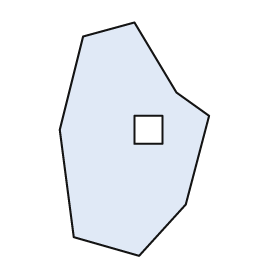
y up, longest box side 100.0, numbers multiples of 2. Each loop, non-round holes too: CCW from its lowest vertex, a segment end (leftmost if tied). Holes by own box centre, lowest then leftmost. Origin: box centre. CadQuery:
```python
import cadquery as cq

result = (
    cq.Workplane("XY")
    .moveTo(2.0, -50.0)
    .lineTo(22.0, -28.0)
    .lineTo(32.0, 10.0)
    .lineTo(18.0, 20.0)
    .lineTo(0.0, 50.0)
    .lineTo(-22.0, 44.0)
    .lineTo(-32.0, 4.0)
    .lineTo(-26.0, -42.0)
    .close()
    .moveTo(0.0, -2.0)
    .lineTo(12.0, -2.0)
    .lineTo(12.0, 10.0)
    .lineTo(0.0, 10.0)
    .close()
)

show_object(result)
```